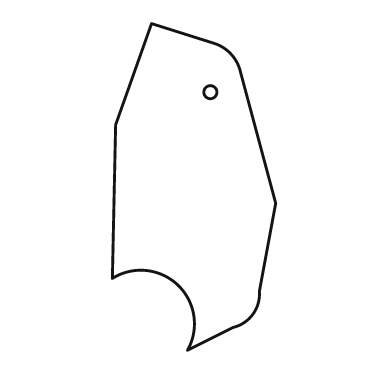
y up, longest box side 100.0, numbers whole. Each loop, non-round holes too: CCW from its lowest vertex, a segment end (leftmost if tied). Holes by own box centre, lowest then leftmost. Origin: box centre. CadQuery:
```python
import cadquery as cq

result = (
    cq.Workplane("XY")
    .moveTo(-2.0, -50.0)
    .lineTo(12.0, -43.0)
    .threePointArc((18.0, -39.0), (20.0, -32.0))
    .lineTo(25.0, -5.0)
    .lineTo(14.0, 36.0)
    .threePointArc((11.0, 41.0), (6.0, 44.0))
    .lineTo(-13.0, 50.0)
    .lineTo(-24.0, 19.0)
    .lineTo(-25.0, -28.0)
    .threePointArc((-5.0, -30.0), (-2.0, -50.0))
    .close()
    .moveTo(5.0, 29.0)
    .circle(2.0)
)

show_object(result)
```